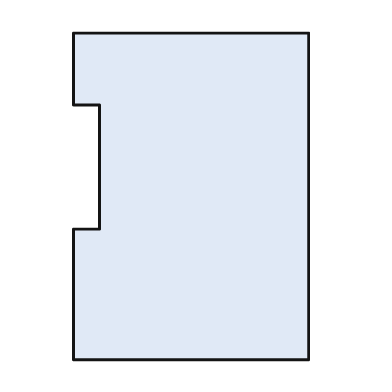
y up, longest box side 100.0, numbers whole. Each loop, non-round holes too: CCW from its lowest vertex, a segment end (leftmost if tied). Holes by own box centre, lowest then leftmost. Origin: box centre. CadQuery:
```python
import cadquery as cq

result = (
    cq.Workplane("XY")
    .moveTo(-36.0, -50.0)
    .lineTo(36.0, -50.0)
    .lineTo(36.0, 50.0)
    .lineTo(-36.0, 50.0)
    .lineTo(-36.0, 28.0)
    .lineTo(-28.0, 28.0)
    .lineTo(-28.0, -10.0)
    .lineTo(-36.0, -10.0)
    .close()
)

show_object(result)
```